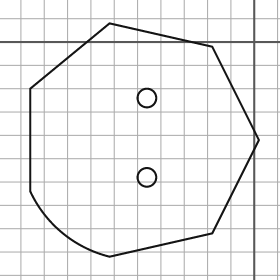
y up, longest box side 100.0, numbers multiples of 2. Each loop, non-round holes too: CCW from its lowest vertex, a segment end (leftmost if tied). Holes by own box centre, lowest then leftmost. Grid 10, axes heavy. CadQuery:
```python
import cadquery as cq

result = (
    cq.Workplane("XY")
    .moveTo(-62.0, -92.0)
    .lineTo(-18.0, -82.0)
    .lineTo(2.0, -42.0)
    .lineTo(-18.0, -2.0)
    .lineTo(-62.0, 8.0)
    .lineTo(-96.0, -20.0)
    .lineTo(-96.0, -64.0)
    .threePointArc((-82.0, -82.0), (-62.0, -92.0))
    .close()
    .moveTo(-46.0, -58.0)
    .circle(4.0)
    .moveTo(-46.0, -24.0)
    .circle(4.0)
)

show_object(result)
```